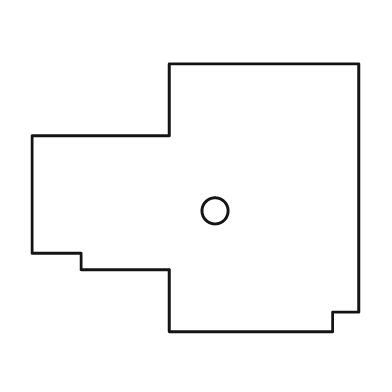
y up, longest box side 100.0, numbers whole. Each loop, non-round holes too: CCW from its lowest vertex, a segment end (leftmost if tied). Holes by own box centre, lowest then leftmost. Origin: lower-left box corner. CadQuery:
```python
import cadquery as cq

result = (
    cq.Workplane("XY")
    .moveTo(42.0, 0.0)
    .lineTo(92.0, 0.0)
    .lineTo(92.0, 6.0)
    .lineTo(100.0, 6.0)
    .lineTo(100.0, 82.0)
    .lineTo(42.0, 82.0)
    .lineTo(42.0, 60.0)
    .lineTo(0.0, 60.0)
    .lineTo(0.0, 24.0)
    .lineTo(15.0, 24.0)
    .lineTo(15.0, 19.0)
    .lineTo(42.0, 19.0)
    .close()
    .moveTo(56.0, 37.0)
    .circle(4.0)
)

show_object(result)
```